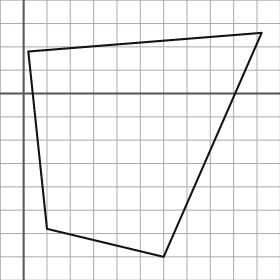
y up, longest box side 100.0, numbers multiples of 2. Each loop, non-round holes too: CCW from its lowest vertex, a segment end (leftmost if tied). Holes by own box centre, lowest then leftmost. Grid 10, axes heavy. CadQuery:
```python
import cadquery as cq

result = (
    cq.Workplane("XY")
    .moveTo(60.0, -70.0)
    .lineTo(102.0, 26.0)
    .lineTo(2.0, 18.0)
    .lineTo(10.0, -58.0)
    .close()
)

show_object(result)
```